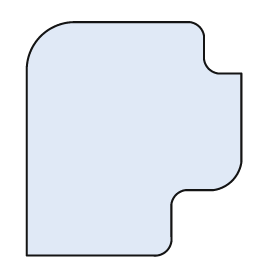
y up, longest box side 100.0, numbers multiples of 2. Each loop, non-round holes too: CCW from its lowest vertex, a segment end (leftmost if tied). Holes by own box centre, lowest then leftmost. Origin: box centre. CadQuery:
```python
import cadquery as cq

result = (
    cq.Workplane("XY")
    .moveTo(-46.0, -50.0)
    .lineTo(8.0, -50.0)
    .threePointArc((14.0, -48.0), (16.0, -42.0))
    .lineTo(16.0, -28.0)
    .threePointArc((18.0, -24.0), (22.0, -22.0))
    .lineTo(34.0, -22.0)
    .threePointArc((42.0, -18.0), (46.0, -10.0))
    .lineTo(46.0, 28.0)
    .lineTo(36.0, 28.0)
    .threePointArc((32.0, 30.0), (30.0, 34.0))
    .lineTo(30.0, 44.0)
    .threePointArc((28.0, 48.0), (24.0, 50.0))
    .lineTo(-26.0, 50.0)
    .threePointArc((-40.0, 44.0), (-46.0, 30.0))
    .close()
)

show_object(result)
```